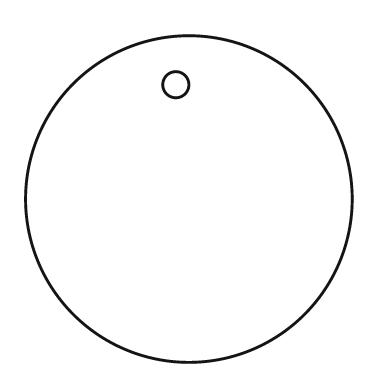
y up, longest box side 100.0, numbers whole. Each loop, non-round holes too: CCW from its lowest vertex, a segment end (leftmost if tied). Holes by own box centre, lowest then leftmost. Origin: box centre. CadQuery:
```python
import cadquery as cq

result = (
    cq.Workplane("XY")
    .moveTo(0.0, 0.0)
    .circle(50.0)
    .moveTo(-4.0, 35.0)
    .circle(4.0)
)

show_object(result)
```